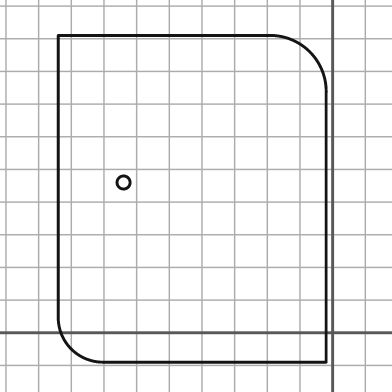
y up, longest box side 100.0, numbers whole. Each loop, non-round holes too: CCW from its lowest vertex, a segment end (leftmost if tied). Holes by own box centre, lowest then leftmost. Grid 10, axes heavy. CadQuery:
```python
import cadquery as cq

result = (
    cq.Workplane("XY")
    .moveTo(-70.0, -9.0)
    .lineTo(-2.0, -9.0)
    .lineTo(-2.0, 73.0)
    .threePointArc((-7.0, 86.0), (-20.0, 91.0))
    .lineTo(-84.0, 91.0)
    .lineTo(-84.0, 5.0)
    .threePointArc((-80.0, -5.0), (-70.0, -9.0))
    .close()
    .moveTo(-64.0, 46.0)
    .circle(2.0)
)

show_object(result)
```